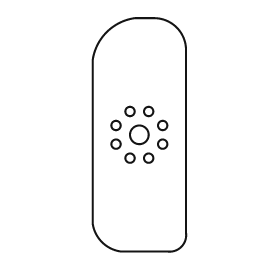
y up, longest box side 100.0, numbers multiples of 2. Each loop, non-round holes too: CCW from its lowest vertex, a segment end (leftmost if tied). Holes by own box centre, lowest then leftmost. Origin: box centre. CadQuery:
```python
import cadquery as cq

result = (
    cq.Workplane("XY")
    .moveTo(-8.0, -50.0)
    .lineTo(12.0, -50.0)
    .threePointArc((18.0, -48.0), (20.0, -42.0))
    .lineTo(20.0, 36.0)
    .threePointArc((16.0, 46.0), (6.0, 50.0))
    .lineTo(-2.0, 50.0)
    .threePointArc((-14.0, 44.0), (-20.0, 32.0))
    .lineTo(-20.0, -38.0)
    .threePointArc((-16.0, -46.0), (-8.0, -50.0))
    .close()
    .moveTo(-4.0, -10.0)
    .circle(2.0)
    .moveTo(4.0, -10.0)
    .circle(2.0)
    .moveTo(-10.0, -4.0)
    .circle(2.0)
    .moveTo(10.0, -4.0)
    .circle(2.0)
    .moveTo(0.0, 0.0)
    .circle(4.0)
    .moveTo(-10.0, 4.0)
    .circle(2.0)
    .moveTo(10.0, 4.0)
    .circle(2.0)
    .moveTo(-4.0, 10.0)
    .circle(2.0)
    .moveTo(4.0, 10.0)
    .circle(2.0)
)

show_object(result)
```